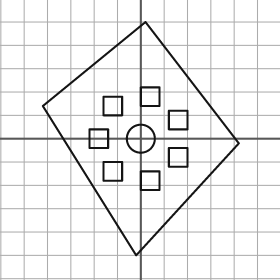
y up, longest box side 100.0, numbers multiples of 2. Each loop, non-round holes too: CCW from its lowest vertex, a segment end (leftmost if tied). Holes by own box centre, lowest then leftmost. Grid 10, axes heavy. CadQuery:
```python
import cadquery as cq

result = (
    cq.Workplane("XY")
    .moveTo(-2.0, -50.0)
    .lineTo(42.0, -2.0)
    .lineTo(2.0, 50.0)
    .lineTo(-42.0, 14.0)
    .close()
    .moveTo(0.0, -22.0)
    .lineTo(8.0, -22.0)
    .lineTo(8.0, -14.0)
    .lineTo(0.0, -14.0)
    .close()
    .moveTo(-16.0, -18.0)
    .lineTo(-8.0, -18.0)
    .lineTo(-8.0, -10.0)
    .lineTo(-16.0, -10.0)
    .close()
    .moveTo(12.0, -12.0)
    .lineTo(20.0, -12.0)
    .lineTo(20.0, -4.0)
    .lineTo(12.0, -4.0)
    .close()
    .moveTo(-22.0, -4.0)
    .lineTo(-14.0, -4.0)
    .lineTo(-14.0, 4.0)
    .lineTo(-22.0, 4.0)
    .close()
    .moveTo(0.0, 0.0)
    .circle(6.0)
    .moveTo(12.0, 4.0)
    .lineTo(20.0, 4.0)
    .lineTo(20.0, 12.0)
    .lineTo(12.0, 12.0)
    .close()
    .moveTo(-16.0, 10.0)
    .lineTo(-8.0, 10.0)
    .lineTo(-8.0, 18.0)
    .lineTo(-16.0, 18.0)
    .close()
    .moveTo(0.0, 14.0)
    .lineTo(8.0, 14.0)
    .lineTo(8.0, 22.0)
    .lineTo(0.0, 22.0)
    .close()
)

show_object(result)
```